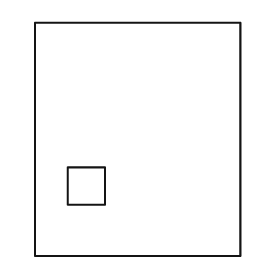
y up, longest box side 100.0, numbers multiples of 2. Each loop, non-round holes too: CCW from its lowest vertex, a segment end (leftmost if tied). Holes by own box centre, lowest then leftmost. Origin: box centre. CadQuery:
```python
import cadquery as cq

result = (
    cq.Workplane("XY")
    .moveTo(-44.0, -50.0)
    .lineTo(44.0, -50.0)
    .lineTo(44.0, 50.0)
    .lineTo(-44.0, 50.0)
    .close()
    .moveTo(-30.0, -28.0)
    .lineTo(-14.0, -28.0)
    .lineTo(-14.0, -12.0)
    .lineTo(-30.0, -12.0)
    .close()
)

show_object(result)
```